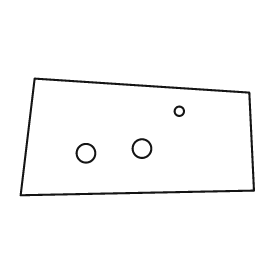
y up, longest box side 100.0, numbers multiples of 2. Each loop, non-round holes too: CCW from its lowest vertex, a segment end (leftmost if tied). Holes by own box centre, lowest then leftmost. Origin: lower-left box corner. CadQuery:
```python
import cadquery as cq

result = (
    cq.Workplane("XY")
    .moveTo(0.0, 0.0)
    .lineTo(100.0, 2.0)
    .lineTo(98.0, 44.0)
    .lineTo(6.0, 50.0)
    .close()
    .moveTo(28.0, 18.0)
    .circle(4.0)
    .moveTo(52.0, 20.0)
    .circle(4.0)
    .moveTo(68.0, 36.0)
    .circle(2.0)
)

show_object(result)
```